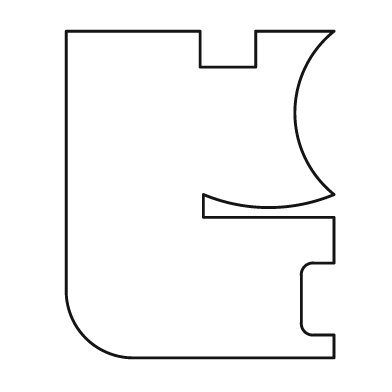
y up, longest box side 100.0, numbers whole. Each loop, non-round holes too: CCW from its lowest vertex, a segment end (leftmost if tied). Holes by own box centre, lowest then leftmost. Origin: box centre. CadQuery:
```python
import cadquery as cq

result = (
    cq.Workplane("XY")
    .moveTo(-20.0, -50.0)
    .lineTo(41.0, -50.0)
    .lineTo(41.0, -43.0)
    .lineTo(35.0, -43.0)
    .threePointArc((32.0, -42.0), (31.0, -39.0))
    .lineTo(31.0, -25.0)
    .threePointArc((32.0, -22.0), (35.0, -21.0))
    .lineTo(41.0, -21.0)
    .lineTo(41.0, -7.0)
    .lineTo(1.0, -7.0)
    .lineTo(1.0, 0.0)
    .threePointArc((21.0, -4.0), (41.0, 0.0))
    .threePointArc((29.0, 25.0), (41.0, 50.0))
    .lineTo(17.0, 50.0)
    .lineTo(17.0, 39.0)
    .lineTo(0.0, 39.0)
    .lineTo(0.0, 50.0)
    .lineTo(-41.0, 50.0)
    .lineTo(-41.0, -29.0)
    .threePointArc((-35.0, -44.0), (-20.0, -50.0))
    .close()
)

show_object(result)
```